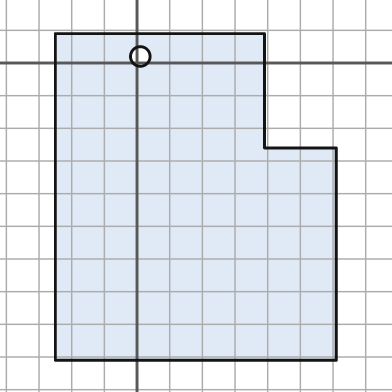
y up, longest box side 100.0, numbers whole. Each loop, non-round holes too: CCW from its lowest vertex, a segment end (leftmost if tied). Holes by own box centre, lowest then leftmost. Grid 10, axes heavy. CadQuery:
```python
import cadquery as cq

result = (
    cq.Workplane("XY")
    .moveTo(-25.0, -91.0)
    .lineTo(61.0, -91.0)
    .lineTo(61.0, -26.0)
    .lineTo(39.0, -26.0)
    .lineTo(39.0, 9.0)
    .lineTo(-25.0, 9.0)
    .close()
    .moveTo(1.0, 2.0)
    .circle(3.0)
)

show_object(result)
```